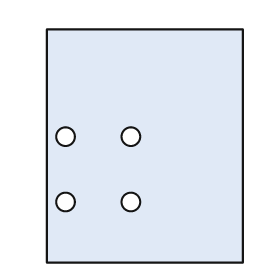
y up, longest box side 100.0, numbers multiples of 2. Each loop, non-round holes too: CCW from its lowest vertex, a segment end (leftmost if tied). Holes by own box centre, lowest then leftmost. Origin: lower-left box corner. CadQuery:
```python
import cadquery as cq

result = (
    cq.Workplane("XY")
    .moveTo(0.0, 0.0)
    .lineTo(84.0, 0.0)
    .lineTo(84.0, 100.0)
    .lineTo(0.0, 100.0)
    .close()
    .moveTo(8.0, 26.0)
    .circle(4.0)
    .moveTo(36.0, 26.0)
    .circle(4.0)
    .moveTo(8.0, 54.0)
    .circle(4.0)
    .moveTo(36.0, 54.0)
    .circle(4.0)
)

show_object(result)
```